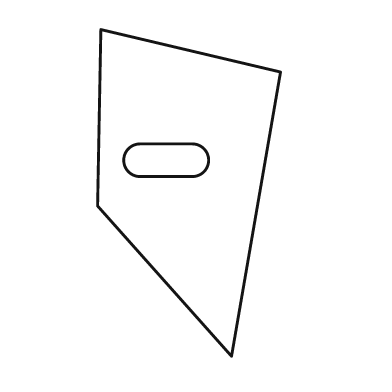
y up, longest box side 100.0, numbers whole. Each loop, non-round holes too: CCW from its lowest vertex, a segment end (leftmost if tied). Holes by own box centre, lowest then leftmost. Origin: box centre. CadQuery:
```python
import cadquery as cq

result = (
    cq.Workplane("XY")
    .moveTo(13.0, -50.0)
    .lineTo(28.0, 37.0)
    .lineTo(-27.0, 50.0)
    .lineTo(-28.0, -4.0)
    .close()
    .moveTo(-15.0, 5.0)
    .lineTo(1.0, 5.0)
    .threePointArc((6.0, 10.0), (1.0, 15.0))
    .lineTo(-15.0, 15.0)
    .threePointArc((-20.0, 10.0), (-15.0, 5.0))
    .close()
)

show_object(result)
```